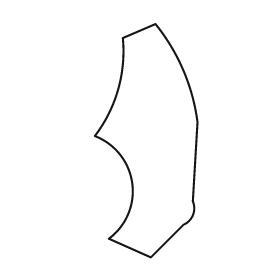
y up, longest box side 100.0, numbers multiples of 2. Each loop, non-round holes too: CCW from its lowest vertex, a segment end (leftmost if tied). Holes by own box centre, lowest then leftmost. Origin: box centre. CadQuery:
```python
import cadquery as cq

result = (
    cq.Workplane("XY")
    .moveTo(2.0, -50.0)
    .lineTo(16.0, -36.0)
    .threePointArc((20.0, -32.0), (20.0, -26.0))
    .lineTo(22.0, 8.0)
    .threePointArc((16.0, 30.0), (4.0, 50.0))
    .lineTo(-10.0, 44.0)
    .threePointArc((-12.0, 22.0), (-22.0, 2.0))
    .threePointArc((-6.0, -18.0), (-16.0, -42.0))
    .close()
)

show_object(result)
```